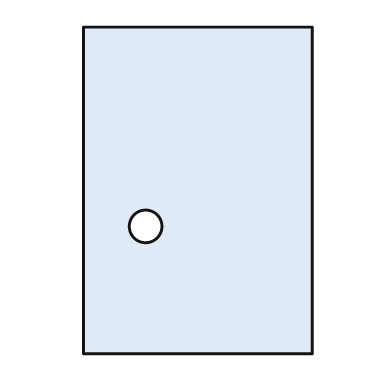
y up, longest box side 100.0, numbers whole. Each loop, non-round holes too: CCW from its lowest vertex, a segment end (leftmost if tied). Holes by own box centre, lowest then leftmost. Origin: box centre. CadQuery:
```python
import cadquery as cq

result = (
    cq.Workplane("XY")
    .moveTo(-35.0, -50.0)
    .lineTo(35.0, -50.0)
    .lineTo(35.0, 50.0)
    .lineTo(-35.0, 50.0)
    .close()
    .moveTo(-16.0, -11.0)
    .circle(5.0)
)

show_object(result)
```